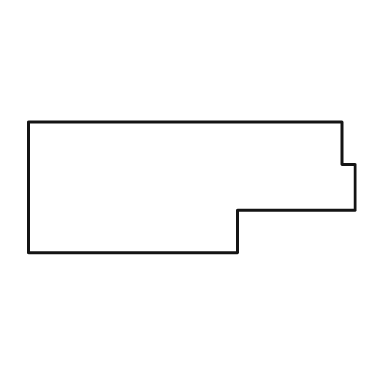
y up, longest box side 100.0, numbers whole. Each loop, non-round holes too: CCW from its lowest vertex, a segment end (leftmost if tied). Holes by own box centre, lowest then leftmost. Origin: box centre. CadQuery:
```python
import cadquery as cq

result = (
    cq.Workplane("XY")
    .moveTo(-50.0, -20.0)
    .lineTo(14.0, -20.0)
    .lineTo(14.0, -7.0)
    .lineTo(50.0, -7.0)
    .lineTo(50.0, 7.0)
    .lineTo(46.0, 7.0)
    .lineTo(46.0, 20.0)
    .lineTo(-50.0, 20.0)
    .close()
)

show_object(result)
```